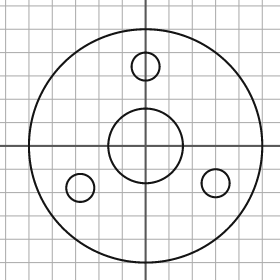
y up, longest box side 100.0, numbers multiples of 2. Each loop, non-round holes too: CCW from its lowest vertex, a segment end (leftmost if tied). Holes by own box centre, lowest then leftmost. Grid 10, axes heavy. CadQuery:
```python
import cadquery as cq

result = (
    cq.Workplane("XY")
    .moveTo(0.0, 0.0)
    .circle(50.0)
    .moveTo(-28.0, -18.0)
    .circle(6.0)
    .moveTo(30.0, -16.0)
    .circle(6.0)
    .moveTo(0.0, 0.0)
    .circle(16.0)
    .moveTo(0.0, 34.0)
    .circle(6.0)
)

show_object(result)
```